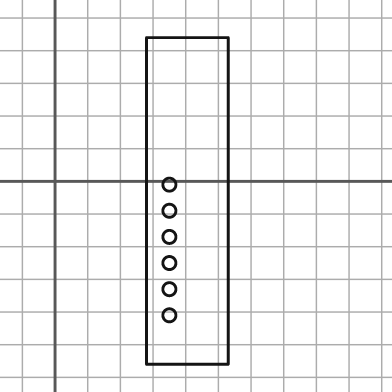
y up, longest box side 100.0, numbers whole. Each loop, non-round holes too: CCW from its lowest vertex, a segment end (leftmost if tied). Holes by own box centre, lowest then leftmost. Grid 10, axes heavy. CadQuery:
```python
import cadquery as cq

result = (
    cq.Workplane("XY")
    .moveTo(28.0, -56.0)
    .lineTo(53.0, -56.0)
    .lineTo(53.0, 44.0)
    .lineTo(28.0, 44.0)
    .close()
    .moveTo(35.0, -41.0)
    .circle(2.0)
    .moveTo(35.0, -33.0)
    .circle(2.0)
    .moveTo(35.0, -25.0)
    .circle(2.0)
    .moveTo(35.0, -17.0)
    .circle(2.0)
    .moveTo(35.0, -9.0)
    .circle(2.0)
    .moveTo(35.0, -1.0)
    .circle(2.0)
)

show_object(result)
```